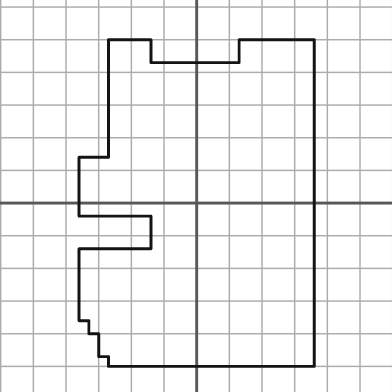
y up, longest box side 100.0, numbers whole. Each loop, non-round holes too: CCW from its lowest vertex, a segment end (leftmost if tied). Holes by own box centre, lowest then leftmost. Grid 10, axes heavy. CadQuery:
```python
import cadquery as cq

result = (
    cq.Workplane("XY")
    .moveTo(-27.0, -50.0)
    .lineTo(36.0, -50.0)
    .lineTo(36.0, 50.0)
    .lineTo(13.0, 50.0)
    .lineTo(13.0, 43.0)
    .lineTo(-14.0, 43.0)
    .lineTo(-14.0, 50.0)
    .lineTo(-27.0, 50.0)
    .lineTo(-27.0, 14.0)
    .lineTo(-36.0, 14.0)
    .lineTo(-36.0, -4.0)
    .lineTo(-14.0, -4.0)
    .lineTo(-14.0, -14.0)
    .lineTo(-36.0, -14.0)
    .lineTo(-36.0, -36.0)
    .lineTo(-33.0, -36.0)
    .lineTo(-33.0, -40.0)
    .lineTo(-30.0, -40.0)
    .lineTo(-30.0, -47.0)
    .lineTo(-27.0, -47.0)
    .close()
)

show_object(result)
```